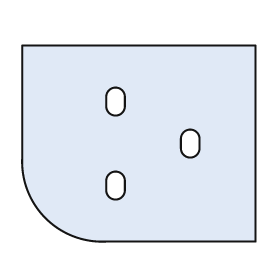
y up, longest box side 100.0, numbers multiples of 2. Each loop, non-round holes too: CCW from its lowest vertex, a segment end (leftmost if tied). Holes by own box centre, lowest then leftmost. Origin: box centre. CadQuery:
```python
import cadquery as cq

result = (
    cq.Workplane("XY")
    .moveTo(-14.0, -42.0)
    .lineTo(50.0, -42.0)
    .lineTo(50.0, 42.0)
    .lineTo(-50.0, 42.0)
    .lineTo(-50.0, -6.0)
    .threePointArc((-40.0, -32.0), (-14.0, -42.0))
    .close()
    .moveTo(-14.0, -20.0)
    .threePointArc((-10.0, -24.0), (-6.0, -20.0))
    .lineTo(-6.0, -16.0)
    .threePointArc((-10.0, -12.0), (-14.0, -16.0))
    .close()
    .moveTo(18.0, -2.0)
    .threePointArc((22.0, -6.0), (26.0, -2.0))
    .lineTo(26.0, 2.0)
    .threePointArc((22.0, 6.0), (18.0, 2.0))
    .close()
    .moveTo(-14.0, 16.0)
    .threePointArc((-10.0, 12.0), (-6.0, 16.0))
    .lineTo(-6.0, 20.0)
    .threePointArc((-10.0, 24.0), (-14.0, 20.0))
    .close()
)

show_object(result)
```